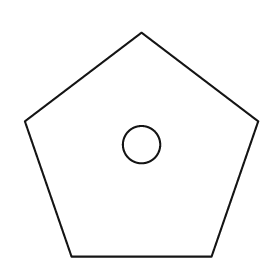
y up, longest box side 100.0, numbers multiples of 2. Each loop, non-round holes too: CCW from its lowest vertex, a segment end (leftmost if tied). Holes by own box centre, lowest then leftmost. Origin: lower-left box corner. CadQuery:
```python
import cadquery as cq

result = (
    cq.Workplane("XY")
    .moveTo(20.0, 0.0)
    .lineTo(80.0, 0.0)
    .lineTo(100.0, 58.0)
    .lineTo(50.0, 96.0)
    .lineTo(0.0, 58.0)
    .close()
    .moveTo(50.0, 48.0)
    .circle(8.0)
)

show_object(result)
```